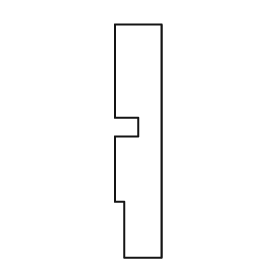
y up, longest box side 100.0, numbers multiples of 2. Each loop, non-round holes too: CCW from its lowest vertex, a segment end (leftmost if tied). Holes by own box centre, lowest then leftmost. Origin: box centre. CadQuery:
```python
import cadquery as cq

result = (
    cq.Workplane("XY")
    .moveTo(-6.0, -50.0)
    .lineTo(10.0, -50.0)
    .lineTo(10.0, 50.0)
    .lineTo(-10.0, 50.0)
    .lineTo(-10.0, 10.0)
    .lineTo(0.0, 10.0)
    .lineTo(0.0, 2.0)
    .lineTo(-10.0, 2.0)
    .lineTo(-10.0, -26.0)
    .lineTo(-6.0, -26.0)
    .close()
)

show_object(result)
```